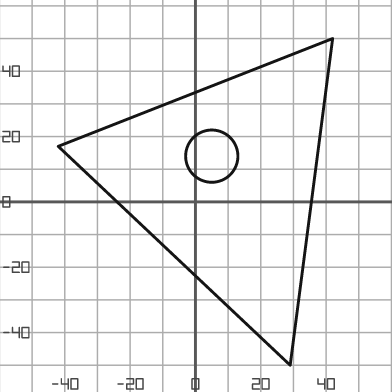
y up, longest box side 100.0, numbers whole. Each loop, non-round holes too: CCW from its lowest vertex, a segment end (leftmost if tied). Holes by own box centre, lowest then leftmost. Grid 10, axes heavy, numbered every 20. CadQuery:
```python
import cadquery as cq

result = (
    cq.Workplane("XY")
    .moveTo(29.0, -50.0)
    .lineTo(42.0, 50.0)
    .lineTo(-42.0, 17.0)
    .close()
    .moveTo(5.0, 14.0)
    .circle(8.0)
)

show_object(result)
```